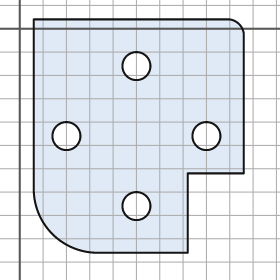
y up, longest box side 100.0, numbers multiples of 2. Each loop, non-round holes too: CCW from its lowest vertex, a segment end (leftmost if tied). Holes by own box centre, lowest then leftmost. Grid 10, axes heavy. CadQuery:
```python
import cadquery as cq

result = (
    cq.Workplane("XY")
    .moveTo(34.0, -96.0)
    .lineTo(72.0, -96.0)
    .lineTo(72.0, -62.0)
    .lineTo(96.0, -62.0)
    .lineTo(96.0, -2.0)
    .threePointArc((94.0, 2.0), (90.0, 4.0))
    .lineTo(6.0, 4.0)
    .lineTo(6.0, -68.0)
    .threePointArc((14.0, -88.0), (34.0, -96.0))
    .close()
    .moveTo(50.0, -76.0)
    .circle(6.0)
    .moveTo(20.0, -46.0)
    .circle(6.0)
    .moveTo(80.0, -46.0)
    .circle(6.0)
    .moveTo(50.0, -16.0)
    .circle(6.0)
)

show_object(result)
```